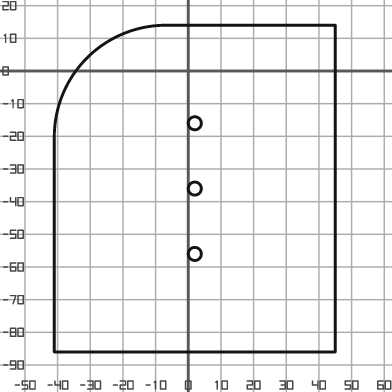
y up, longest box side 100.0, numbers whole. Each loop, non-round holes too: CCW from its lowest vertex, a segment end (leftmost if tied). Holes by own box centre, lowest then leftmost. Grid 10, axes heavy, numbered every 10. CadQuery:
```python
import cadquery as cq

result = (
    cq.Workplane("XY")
    .moveTo(-41.0, -86.0)
    .lineTo(45.0, -86.0)
    .lineTo(45.0, 14.0)
    .lineTo(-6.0, 14.0)
    .threePointArc((-31.0, 4.0), (-41.0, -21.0))
    .close()
    .moveTo(2.0, -56.0)
    .circle(2.0)
    .moveTo(2.0, -36.0)
    .circle(2.0)
    .moveTo(2.0, -16.0)
    .circle(2.0)
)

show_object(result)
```